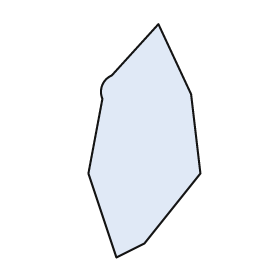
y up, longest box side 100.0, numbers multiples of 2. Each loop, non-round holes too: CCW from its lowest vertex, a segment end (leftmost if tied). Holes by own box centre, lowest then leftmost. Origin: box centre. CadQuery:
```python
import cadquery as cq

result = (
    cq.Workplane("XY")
    .moveTo(-12.0, -50.0)
    .lineTo(0.0, -44.0)
    .lineTo(24.0, -14.0)
    .lineTo(20.0, 20.0)
    .lineTo(6.0, 50.0)
    .lineTo(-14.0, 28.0)
    .threePointArc((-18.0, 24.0), (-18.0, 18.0))
    .lineTo(-24.0, -14.0)
    .close()
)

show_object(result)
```